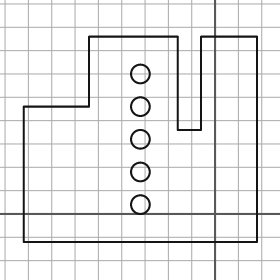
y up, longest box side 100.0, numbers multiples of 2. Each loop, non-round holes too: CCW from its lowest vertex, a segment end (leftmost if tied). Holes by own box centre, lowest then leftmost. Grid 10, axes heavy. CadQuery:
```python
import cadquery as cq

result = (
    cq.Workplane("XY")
    .moveTo(-82.0, -12.0)
    .lineTo(18.0, -12.0)
    .lineTo(18.0, 76.0)
    .lineTo(-6.0, 76.0)
    .lineTo(-6.0, 36.0)
    .lineTo(-16.0, 36.0)
    .lineTo(-16.0, 76.0)
    .lineTo(-54.0, 76.0)
    .lineTo(-54.0, 46.0)
    .lineTo(-82.0, 46.0)
    .close()
    .moveTo(-32.0, 4.0)
    .circle(4.0)
    .moveTo(-32.0, 18.0)
    .circle(4.0)
    .moveTo(-32.0, 32.0)
    .circle(4.0)
    .moveTo(-32.0, 46.0)
    .circle(4.0)
    .moveTo(-32.0, 60.0)
    .circle(4.0)
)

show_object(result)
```